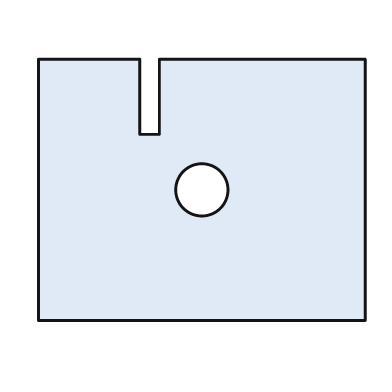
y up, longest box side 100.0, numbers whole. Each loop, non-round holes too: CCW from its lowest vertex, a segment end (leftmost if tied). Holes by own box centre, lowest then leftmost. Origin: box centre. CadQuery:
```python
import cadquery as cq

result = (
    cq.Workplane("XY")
    .moveTo(-50.0, -40.0)
    .lineTo(50.0, -40.0)
    .lineTo(50.0, 40.0)
    .lineTo(-13.0, 40.0)
    .lineTo(-13.0, 17.0)
    .lineTo(-19.0, 17.0)
    .lineTo(-19.0, 40.0)
    .lineTo(-50.0, 40.0)
    .close()
    .moveTo(0.0, 0.0)
    .circle(8.0)
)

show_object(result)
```